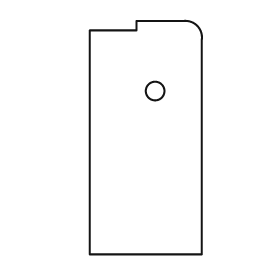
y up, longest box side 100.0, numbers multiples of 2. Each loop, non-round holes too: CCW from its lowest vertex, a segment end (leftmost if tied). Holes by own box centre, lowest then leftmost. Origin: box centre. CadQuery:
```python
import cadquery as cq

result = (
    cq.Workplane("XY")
    .moveTo(-24.0, -50.0)
    .lineTo(24.0, -50.0)
    .lineTo(24.0, 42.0)
    .threePointArc((22.0, 48.0), (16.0, 50.0))
    .lineTo(-4.0, 50.0)
    .lineTo(-4.0, 46.0)
    .lineTo(-24.0, 46.0)
    .close()
    .moveTo(4.0, 20.0)
    .circle(4.0)
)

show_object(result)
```